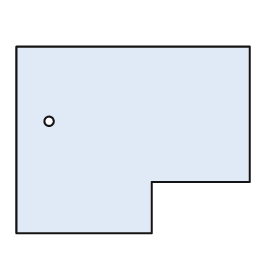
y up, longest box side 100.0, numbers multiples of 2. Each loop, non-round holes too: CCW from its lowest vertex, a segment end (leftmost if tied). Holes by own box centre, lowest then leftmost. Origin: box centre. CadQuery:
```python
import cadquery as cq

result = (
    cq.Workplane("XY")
    .moveTo(-50.0, -40.0)
    .lineTo(8.0, -40.0)
    .lineTo(8.0, -18.0)
    .lineTo(50.0, -18.0)
    .lineTo(50.0, 40.0)
    .lineTo(-50.0, 40.0)
    .close()
    .moveTo(-36.0, 8.0)
    .circle(2.0)
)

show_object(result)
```